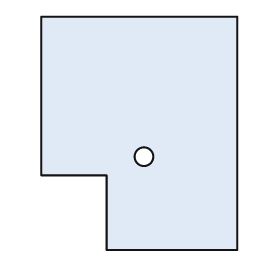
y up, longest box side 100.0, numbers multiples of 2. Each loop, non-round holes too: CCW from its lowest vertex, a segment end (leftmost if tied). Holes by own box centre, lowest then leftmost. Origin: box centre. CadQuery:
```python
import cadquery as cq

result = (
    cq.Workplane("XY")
    .moveTo(-14.0, -50.0)
    .lineTo(42.0, -50.0)
    .lineTo(42.0, 50.0)
    .lineTo(-42.0, 50.0)
    .lineTo(-42.0, -18.0)
    .lineTo(-14.0, -18.0)
    .close()
    .moveTo(2.0, -10.0)
    .circle(4.0)
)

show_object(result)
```